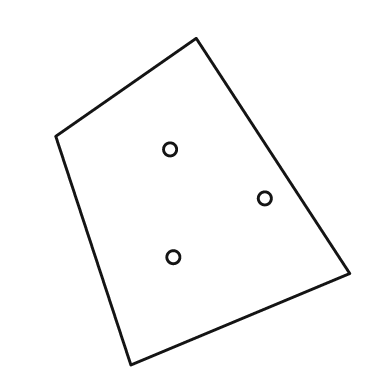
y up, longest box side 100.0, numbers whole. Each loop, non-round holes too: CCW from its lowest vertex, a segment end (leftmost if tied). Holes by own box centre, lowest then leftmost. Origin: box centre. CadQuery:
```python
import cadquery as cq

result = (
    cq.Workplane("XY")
    .moveTo(-22.0, -50.0)
    .lineTo(45.0, -22.0)
    .lineTo(-2.0, 50.0)
    .lineTo(-45.0, 20.0)
    .close()
    .moveTo(-9.0, -17.0)
    .circle(2.0)
    .moveTo(19.0, 1.0)
    .circle(2.0)
    .moveTo(-10.0, 16.0)
    .circle(2.0)
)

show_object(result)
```